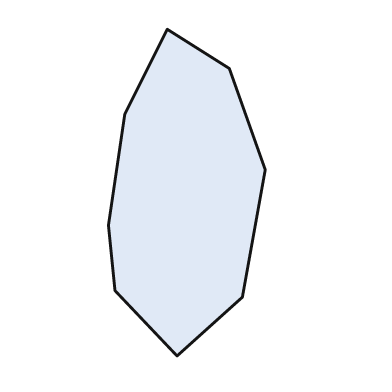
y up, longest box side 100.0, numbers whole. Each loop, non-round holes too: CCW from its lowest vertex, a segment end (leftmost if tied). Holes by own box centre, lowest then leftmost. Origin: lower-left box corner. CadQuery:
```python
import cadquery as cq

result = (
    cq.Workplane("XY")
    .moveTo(21.0, 0.0)
    .lineTo(41.0, 18.0)
    .lineTo(48.0, 57.0)
    .lineTo(37.0, 88.0)
    .lineTo(18.0, 100.0)
    .lineTo(5.0, 74.0)
    .lineTo(0.0, 40.0)
    .lineTo(2.0, 20.0)
    .close()
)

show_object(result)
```